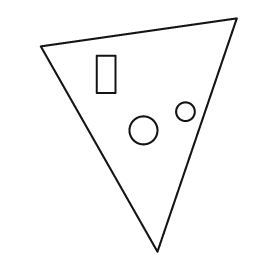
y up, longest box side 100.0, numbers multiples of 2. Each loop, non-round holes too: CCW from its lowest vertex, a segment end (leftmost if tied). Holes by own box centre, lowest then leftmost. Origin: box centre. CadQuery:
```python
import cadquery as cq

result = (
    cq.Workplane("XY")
    .moveTo(8.0, -50.0)
    .lineTo(42.0, 50.0)
    .lineTo(-42.0, 38.0)
    .close()
    .moveTo(2.0, 2.0)
    .circle(6.0)
    .moveTo(20.0, 10.0)
    .circle(4.0)
    .moveTo(-18.0, 18.0)
    .lineTo(-10.0, 18.0)
    .lineTo(-10.0, 34.0)
    .lineTo(-18.0, 34.0)
    .close()
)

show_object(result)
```